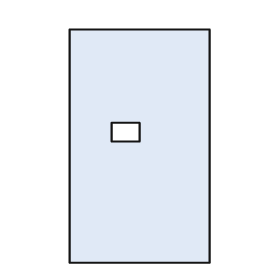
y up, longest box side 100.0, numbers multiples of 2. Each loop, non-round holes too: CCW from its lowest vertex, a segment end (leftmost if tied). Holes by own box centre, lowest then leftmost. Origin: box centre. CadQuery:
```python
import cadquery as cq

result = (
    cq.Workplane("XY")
    .moveTo(-30.0, -50.0)
    .lineTo(30.0, -50.0)
    .lineTo(30.0, 50.0)
    .lineTo(-30.0, 50.0)
    .close()
    .moveTo(-12.0, 2.0)
    .lineTo(0.0, 2.0)
    .lineTo(0.0, 10.0)
    .lineTo(-12.0, 10.0)
    .close()
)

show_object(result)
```